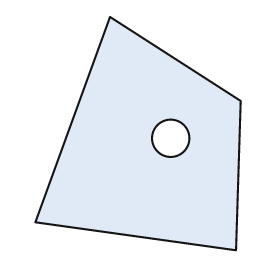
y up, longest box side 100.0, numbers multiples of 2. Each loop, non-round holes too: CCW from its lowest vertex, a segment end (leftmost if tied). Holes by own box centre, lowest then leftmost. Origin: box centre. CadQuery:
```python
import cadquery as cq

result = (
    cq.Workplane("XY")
    .moveTo(42.0, -50.0)
    .lineTo(44.0, 14.0)
    .lineTo(-12.0, 50.0)
    .lineTo(-44.0, -38.0)
    .close()
    .moveTo(14.0, -2.0)
    .circle(8.0)
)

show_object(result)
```